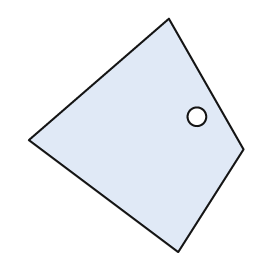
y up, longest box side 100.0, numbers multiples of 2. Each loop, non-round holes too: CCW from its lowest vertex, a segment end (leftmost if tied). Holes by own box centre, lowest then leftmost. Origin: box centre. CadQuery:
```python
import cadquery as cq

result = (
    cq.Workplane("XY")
    .moveTo(18.0, -50.0)
    .lineTo(46.0, -6.0)
    .lineTo(14.0, 50.0)
    .lineTo(-46.0, -2.0)
    .close()
    .moveTo(26.0, 8.0)
    .circle(4.0)
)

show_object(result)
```